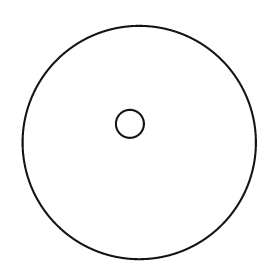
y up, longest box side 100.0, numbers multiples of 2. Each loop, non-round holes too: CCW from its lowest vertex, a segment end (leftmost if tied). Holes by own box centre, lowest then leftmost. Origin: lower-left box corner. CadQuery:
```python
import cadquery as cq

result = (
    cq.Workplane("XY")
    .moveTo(50.0, 50.0)
    .circle(50.0)
    .moveTo(46.0, 58.0)
    .circle(6.0)
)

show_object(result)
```